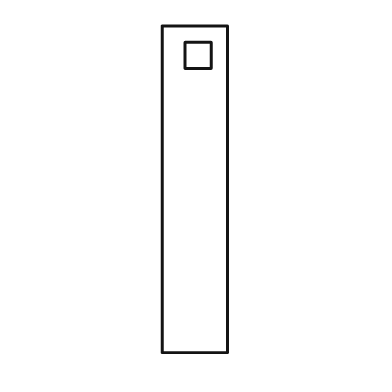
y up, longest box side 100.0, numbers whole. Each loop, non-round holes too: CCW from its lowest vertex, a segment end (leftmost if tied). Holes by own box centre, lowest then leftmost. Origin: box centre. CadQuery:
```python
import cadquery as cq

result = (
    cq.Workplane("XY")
    .moveTo(-10.0, -50.0)
    .lineTo(10.0, -50.0)
    .lineTo(10.0, 50.0)
    .lineTo(-10.0, 50.0)
    .close()
    .moveTo(-3.0, 37.0)
    .lineTo(5.0, 37.0)
    .lineTo(5.0, 45.0)
    .lineTo(-3.0, 45.0)
    .close()
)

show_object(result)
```